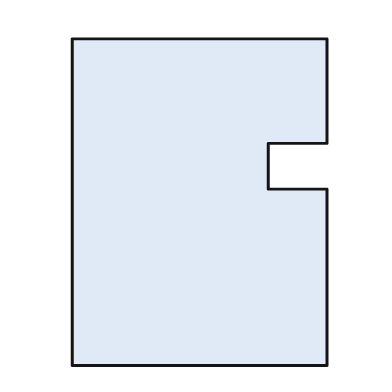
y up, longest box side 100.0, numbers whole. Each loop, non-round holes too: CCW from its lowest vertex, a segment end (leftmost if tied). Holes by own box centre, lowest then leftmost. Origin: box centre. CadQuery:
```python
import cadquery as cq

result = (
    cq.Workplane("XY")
    .moveTo(-39.0, -50.0)
    .lineTo(39.0, -50.0)
    .lineTo(39.0, 4.0)
    .lineTo(21.0, 4.0)
    .lineTo(21.0, 18.0)
    .lineTo(39.0, 18.0)
    .lineTo(39.0, 50.0)
    .lineTo(-39.0, 50.0)
    .close()
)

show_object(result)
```